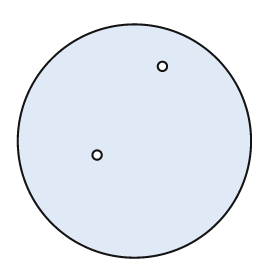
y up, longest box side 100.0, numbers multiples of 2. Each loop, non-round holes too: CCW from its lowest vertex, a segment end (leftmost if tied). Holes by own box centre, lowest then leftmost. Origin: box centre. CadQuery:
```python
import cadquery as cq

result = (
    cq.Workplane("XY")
    .moveTo(0.0, 0.0)
    .circle(50.0)
    .moveTo(-16.0, -6.0)
    .circle(2.0)
    .moveTo(12.0, 32.0)
    .circle(2.0)
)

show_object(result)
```